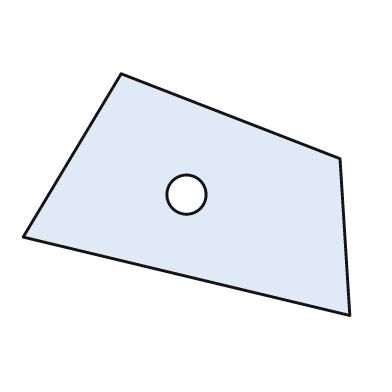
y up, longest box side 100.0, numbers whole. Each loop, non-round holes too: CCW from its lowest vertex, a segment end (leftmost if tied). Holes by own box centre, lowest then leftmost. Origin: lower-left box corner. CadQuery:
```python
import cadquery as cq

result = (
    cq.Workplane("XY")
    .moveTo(100.0, 0.0)
    .lineTo(97.0, 48.0)
    .lineTo(30.0, 74.0)
    .lineTo(0.0, 24.0)
    .close()
    .moveTo(50.0, 37.0)
    .circle(6.0)
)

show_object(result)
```